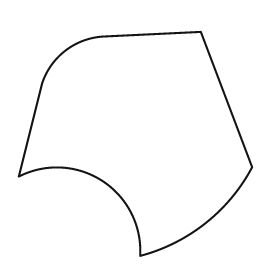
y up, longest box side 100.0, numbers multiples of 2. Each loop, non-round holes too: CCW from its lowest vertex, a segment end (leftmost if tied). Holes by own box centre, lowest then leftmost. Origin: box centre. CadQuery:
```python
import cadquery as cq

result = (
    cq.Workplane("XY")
    .moveTo(2.0, -48.0)
    .threePointArc((30.0, -34.0), (50.0, -10.0))
    .lineTo(28.0, 48.0)
    .lineTo(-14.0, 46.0)
    .threePointArc((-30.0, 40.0), (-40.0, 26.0))
    .lineTo(-50.0, -14.0)
    .threePointArc((-14.0, -16.0), (2.0, -48.0))
    .close()
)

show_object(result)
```